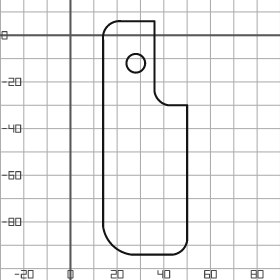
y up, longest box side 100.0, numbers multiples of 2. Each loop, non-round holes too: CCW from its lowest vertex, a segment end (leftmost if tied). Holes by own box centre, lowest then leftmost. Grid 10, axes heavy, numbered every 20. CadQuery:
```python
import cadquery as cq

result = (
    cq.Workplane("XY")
    .moveTo(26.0, -94.0)
    .lineTo(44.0, -94.0)
    .threePointArc((48.0, -92.0), (50.0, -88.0))
    .lineTo(50.0, -30.0)
    .lineTo(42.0, -30.0)
    .threePointArc((38.0, -28.0), (36.0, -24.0))
    .lineTo(36.0, 6.0)
    .lineTo(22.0, 6.0)
    .threePointArc((16.0, 4.0), (14.0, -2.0))
    .lineTo(14.0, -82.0)
    .threePointArc((18.0, -90.0), (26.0, -94.0))
    .close()
    .moveTo(28.0, -12.0)
    .circle(4.0)
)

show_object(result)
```